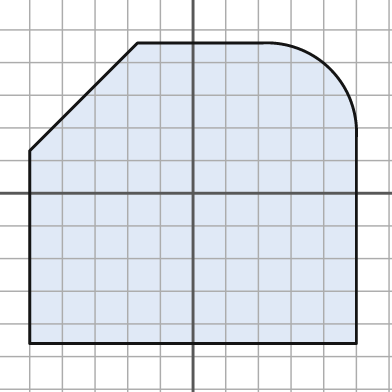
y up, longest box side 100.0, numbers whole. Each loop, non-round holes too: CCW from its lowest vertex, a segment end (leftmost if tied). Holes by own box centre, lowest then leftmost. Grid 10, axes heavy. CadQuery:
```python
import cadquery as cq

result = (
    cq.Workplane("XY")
    .moveTo(-50.0, -46.0)
    .lineTo(50.0, -46.0)
    .lineTo(50.0, 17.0)
    .threePointArc((42.0, 38.0), (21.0, 46.0))
    .lineTo(-17.0, 46.0)
    .lineTo(-50.0, 13.0)
    .close()
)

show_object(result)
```